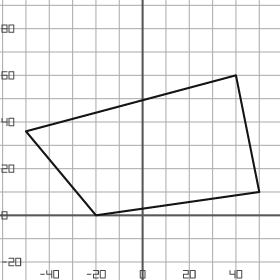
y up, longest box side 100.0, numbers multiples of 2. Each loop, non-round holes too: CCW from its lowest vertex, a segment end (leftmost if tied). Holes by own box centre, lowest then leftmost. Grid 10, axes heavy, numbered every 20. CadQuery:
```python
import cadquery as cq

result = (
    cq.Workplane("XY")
    .moveTo(-20.0, 0.0)
    .lineTo(50.0, 10.0)
    .lineTo(40.0, 60.0)
    .lineTo(-50.0, 36.0)
    .close()
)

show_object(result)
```